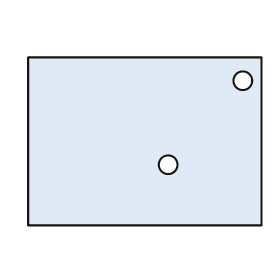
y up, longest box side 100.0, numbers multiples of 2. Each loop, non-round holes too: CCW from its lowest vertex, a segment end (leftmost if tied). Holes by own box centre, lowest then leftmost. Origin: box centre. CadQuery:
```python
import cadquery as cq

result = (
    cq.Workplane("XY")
    .moveTo(-50.0, -36.0)
    .lineTo(50.0, -36.0)
    .lineTo(50.0, 36.0)
    .lineTo(-50.0, 36.0)
    .close()
    .moveTo(10.0, -10.0)
    .circle(4.0)
    .moveTo(42.0, 26.0)
    .circle(4.0)
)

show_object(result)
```